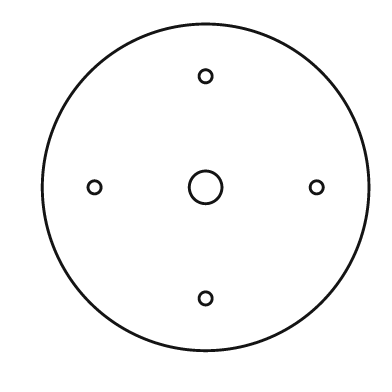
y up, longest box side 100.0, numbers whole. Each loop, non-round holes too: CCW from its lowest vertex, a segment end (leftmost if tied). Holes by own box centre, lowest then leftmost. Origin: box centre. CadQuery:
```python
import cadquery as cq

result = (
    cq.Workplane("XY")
    .moveTo(0.0, 0.0)
    .circle(50.0)
    .moveTo(0.0, -34.0)
    .circle(2.0)
    .moveTo(-34.0, 0.0)
    .circle(2.0)
    .moveTo(0.0, 0.0)
    .circle(5.0)
    .moveTo(34.0, 0.0)
    .circle(2.0)
    .moveTo(0.0, 34.0)
    .circle(2.0)
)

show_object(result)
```